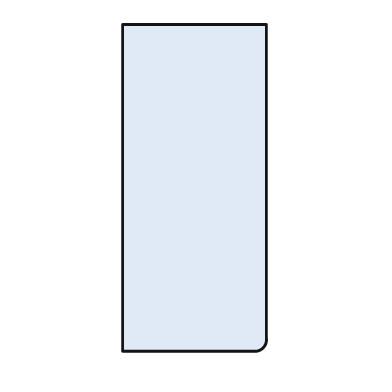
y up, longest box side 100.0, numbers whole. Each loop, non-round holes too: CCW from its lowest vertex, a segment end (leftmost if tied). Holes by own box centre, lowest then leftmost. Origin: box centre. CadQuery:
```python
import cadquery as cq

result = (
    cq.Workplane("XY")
    .moveTo(-22.0, -50.0)
    .lineTo(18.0, -50.0)
    .threePointArc((21.0, -49.0), (22.0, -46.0))
    .lineTo(22.0, 50.0)
    .lineTo(-22.0, 50.0)
    .close()
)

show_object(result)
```